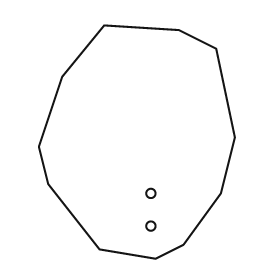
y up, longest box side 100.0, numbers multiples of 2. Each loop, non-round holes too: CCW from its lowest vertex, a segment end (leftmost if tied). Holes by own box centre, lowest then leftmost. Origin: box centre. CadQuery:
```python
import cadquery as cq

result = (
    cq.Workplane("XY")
    .moveTo(8.0, -50.0)
    .lineTo(20.0, -44.0)
    .lineTo(36.0, -22.0)
    .lineTo(42.0, 2.0)
    .lineTo(34.0, 40.0)
    .lineTo(18.0, 48.0)
    .lineTo(-14.0, 50.0)
    .lineTo(-32.0, 28.0)
    .lineTo(-42.0, -2.0)
    .lineTo(-38.0, -18.0)
    .lineTo(-16.0, -46.0)
    .close()
    .moveTo(6.0, -36.0)
    .circle(2.0)
    .moveTo(6.0, -22.0)
    .circle(2.0)
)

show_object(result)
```